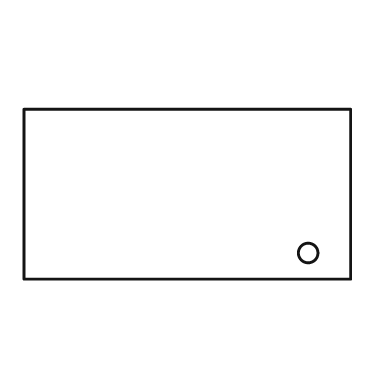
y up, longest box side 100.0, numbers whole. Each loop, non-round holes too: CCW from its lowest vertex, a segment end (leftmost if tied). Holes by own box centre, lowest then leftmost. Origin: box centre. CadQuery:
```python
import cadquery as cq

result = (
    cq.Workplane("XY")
    .moveTo(-50.0, -26.0)
    .lineTo(50.0, -26.0)
    .lineTo(50.0, 26.0)
    .lineTo(-50.0, 26.0)
    .close()
    .moveTo(37.0, -18.0)
    .circle(3.0)
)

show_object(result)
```